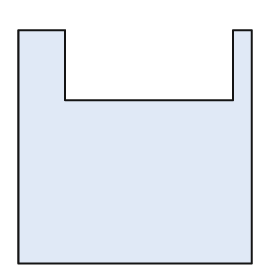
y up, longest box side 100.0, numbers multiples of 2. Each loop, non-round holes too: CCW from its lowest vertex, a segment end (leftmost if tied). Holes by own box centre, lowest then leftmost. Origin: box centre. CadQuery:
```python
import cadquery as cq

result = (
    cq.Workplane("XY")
    .moveTo(-50.0, -50.0)
    .lineTo(50.0, -50.0)
    .lineTo(50.0, 50.0)
    .lineTo(42.0, 50.0)
    .lineTo(42.0, 20.0)
    .lineTo(-30.0, 20.0)
    .lineTo(-30.0, 50.0)
    .lineTo(-50.0, 50.0)
    .close()
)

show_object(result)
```